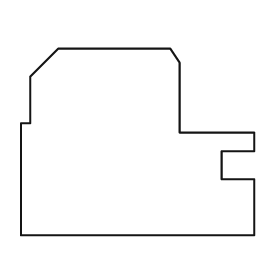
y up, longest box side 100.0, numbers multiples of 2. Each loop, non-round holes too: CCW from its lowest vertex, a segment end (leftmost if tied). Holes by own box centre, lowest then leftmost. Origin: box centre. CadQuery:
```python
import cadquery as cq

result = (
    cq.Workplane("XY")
    .moveTo(-50.0, -40.0)
    .lineTo(50.0, -40.0)
    .lineTo(50.0, -16.0)
    .lineTo(36.0, -16.0)
    .lineTo(36.0, -4.0)
    .lineTo(50.0, -4.0)
    .lineTo(50.0, 4.0)
    .lineTo(18.0, 4.0)
    .lineTo(18.0, 34.0)
    .lineTo(14.0, 40.0)
    .lineTo(-34.0, 40.0)
    .lineTo(-46.0, 28.0)
    .lineTo(-46.0, 8.0)
    .lineTo(-50.0, 8.0)
    .close()
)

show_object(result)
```